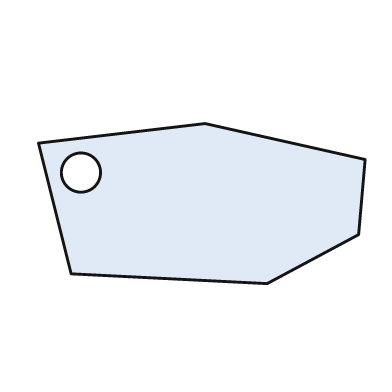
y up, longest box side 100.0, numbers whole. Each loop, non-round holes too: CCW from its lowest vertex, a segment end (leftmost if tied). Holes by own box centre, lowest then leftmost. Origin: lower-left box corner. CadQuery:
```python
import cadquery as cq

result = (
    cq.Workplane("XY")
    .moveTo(70.0, 0.0)
    .lineTo(98.0, 15.0)
    .lineTo(100.0, 38.0)
    .lineTo(51.0, 49.0)
    .lineTo(0.0, 43.0)
    .lineTo(10.0, 3.0)
    .close()
    .moveTo(13.0, 34.0)
    .circle(6.0)
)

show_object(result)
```